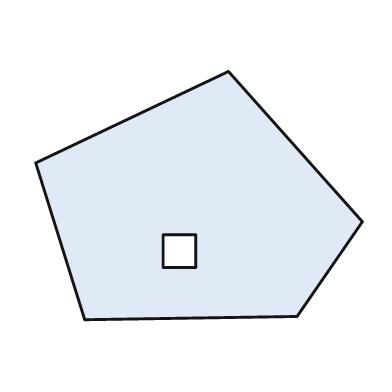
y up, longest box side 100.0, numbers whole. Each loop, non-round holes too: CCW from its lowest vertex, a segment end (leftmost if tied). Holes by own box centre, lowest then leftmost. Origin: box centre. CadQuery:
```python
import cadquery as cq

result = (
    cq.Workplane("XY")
    .moveTo(-35.0, -38.0)
    .lineTo(30.0, -37.0)
    .lineTo(50.0, -8.0)
    .lineTo(9.0, 38.0)
    .lineTo(-50.0, 10.0)
    .close()
    .moveTo(-11.0, -22.0)
    .lineTo(-1.0, -22.0)
    .lineTo(-1.0, -12.0)
    .lineTo(-11.0, -12.0)
    .close()
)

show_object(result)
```